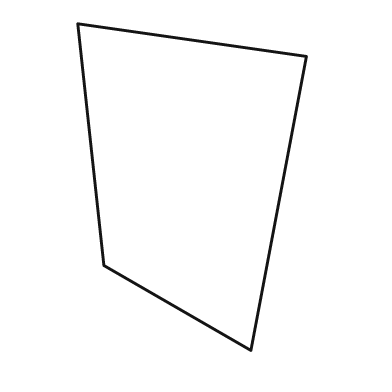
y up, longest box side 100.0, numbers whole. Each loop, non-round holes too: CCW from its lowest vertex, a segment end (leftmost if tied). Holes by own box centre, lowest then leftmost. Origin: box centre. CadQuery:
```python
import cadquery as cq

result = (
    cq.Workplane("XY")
    .moveTo(18.0, -50.0)
    .lineTo(35.0, 40.0)
    .lineTo(-35.0, 50.0)
    .lineTo(-27.0, -24.0)
    .close()
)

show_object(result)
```